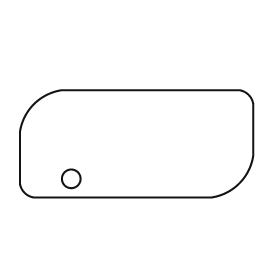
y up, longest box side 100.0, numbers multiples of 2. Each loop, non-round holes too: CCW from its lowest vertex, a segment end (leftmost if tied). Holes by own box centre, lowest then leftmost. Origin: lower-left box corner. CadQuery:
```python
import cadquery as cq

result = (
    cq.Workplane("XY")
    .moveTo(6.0, 0.0)
    .lineTo(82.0, 0.0)
    .threePointArc((94.0, 6.0), (100.0, 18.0))
    .lineTo(100.0, 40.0)
    .threePointArc((98.0, 44.0), (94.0, 46.0))
    .lineTo(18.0, 46.0)
    .threePointArc((6.0, 40.0), (0.0, 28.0))
    .lineTo(0.0, 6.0)
    .threePointArc((2.0, 2.0), (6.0, 0.0))
    .close()
    .moveTo(22.0, 8.0)
    .circle(4.0)
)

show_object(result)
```